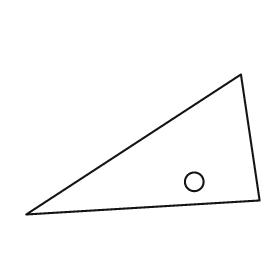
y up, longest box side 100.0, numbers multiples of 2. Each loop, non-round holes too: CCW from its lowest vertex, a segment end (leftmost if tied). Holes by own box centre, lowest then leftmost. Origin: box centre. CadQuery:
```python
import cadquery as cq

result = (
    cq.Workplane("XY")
    .moveTo(-50.0, -30.0)
    .lineTo(50.0, -24.0)
    .lineTo(42.0, 30.0)
    .close()
    .moveTo(22.0, -16.0)
    .circle(4.0)
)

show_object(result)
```